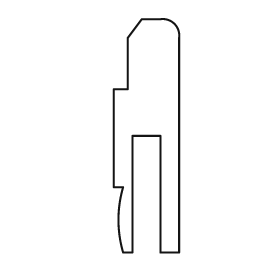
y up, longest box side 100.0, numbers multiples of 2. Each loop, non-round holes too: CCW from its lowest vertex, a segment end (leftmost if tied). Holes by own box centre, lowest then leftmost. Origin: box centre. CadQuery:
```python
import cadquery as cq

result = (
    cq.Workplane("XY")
    .moveTo(-10.0, -50.0)
    .lineTo(-6.0, -50.0)
    .lineTo(-6.0, 0.0)
    .lineTo(6.0, 0.0)
    .lineTo(6.0, -50.0)
    .lineTo(14.0, -50.0)
    .lineTo(14.0, 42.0)
    .threePointArc((12.0, 48.0), (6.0, 50.0))
    .lineTo(-2.0, 50.0)
    .lineTo(-8.0, 42.0)
    .lineTo(-8.0, 20.0)
    .lineTo(-14.0, 20.0)
    .lineTo(-14.0, -22.0)
    .lineTo(-10.0, -22.0)
    .threePointArc((-12.0, -36.0), (-10.0, -50.0))
    .close()
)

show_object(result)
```